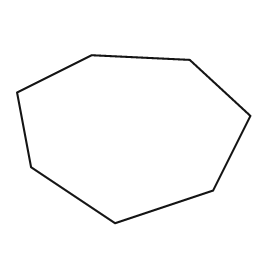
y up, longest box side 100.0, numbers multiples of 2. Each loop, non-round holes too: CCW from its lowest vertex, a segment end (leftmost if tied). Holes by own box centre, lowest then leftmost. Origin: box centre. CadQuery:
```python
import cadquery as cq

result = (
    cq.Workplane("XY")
    .moveTo(-8.0, -36.0)
    .lineTo(34.0, -22.0)
    .lineTo(50.0, 10.0)
    .lineTo(24.0, 34.0)
    .lineTo(-18.0, 36.0)
    .lineTo(-50.0, 20.0)
    .lineTo(-44.0, -12.0)
    .close()
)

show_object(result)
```